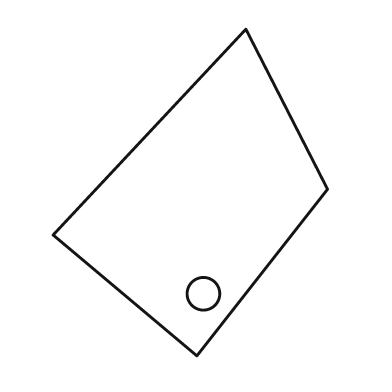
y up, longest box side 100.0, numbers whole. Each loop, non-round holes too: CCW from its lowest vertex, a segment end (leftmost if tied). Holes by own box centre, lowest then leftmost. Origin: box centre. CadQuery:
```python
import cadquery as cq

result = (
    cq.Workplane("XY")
    .moveTo(2.0, -50.0)
    .lineTo(42.0, 1.0)
    .lineTo(17.0, 50.0)
    .lineTo(-42.0, -13.0)
    .close()
    .moveTo(4.0, -31.0)
    .circle(5.0)
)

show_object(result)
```